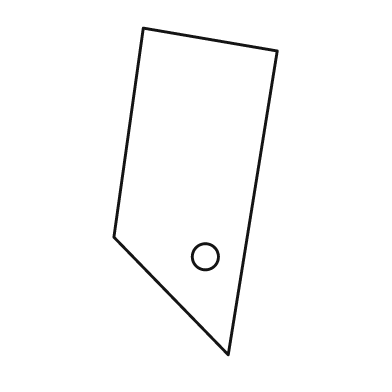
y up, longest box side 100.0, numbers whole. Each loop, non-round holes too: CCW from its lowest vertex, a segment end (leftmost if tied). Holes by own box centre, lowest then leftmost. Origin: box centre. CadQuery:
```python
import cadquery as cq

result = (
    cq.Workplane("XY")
    .moveTo(10.0, -50.0)
    .lineTo(25.0, 43.0)
    .lineTo(-16.0, 50.0)
    .lineTo(-25.0, -14.0)
    .close()
    .moveTo(3.0, -20.0)
    .circle(4.0)
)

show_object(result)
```